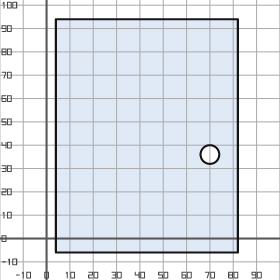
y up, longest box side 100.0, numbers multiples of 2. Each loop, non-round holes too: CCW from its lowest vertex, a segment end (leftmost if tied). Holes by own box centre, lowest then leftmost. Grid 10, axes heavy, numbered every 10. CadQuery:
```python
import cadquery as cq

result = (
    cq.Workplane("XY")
    .moveTo(4.0, -6.0)
    .lineTo(82.0, -6.0)
    .lineTo(82.0, 94.0)
    .lineTo(4.0, 94.0)
    .close()
    .moveTo(70.0, 36.0)
    .circle(4.0)
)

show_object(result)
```